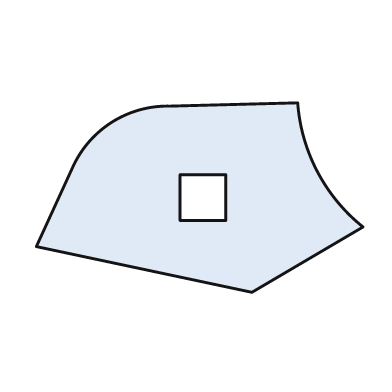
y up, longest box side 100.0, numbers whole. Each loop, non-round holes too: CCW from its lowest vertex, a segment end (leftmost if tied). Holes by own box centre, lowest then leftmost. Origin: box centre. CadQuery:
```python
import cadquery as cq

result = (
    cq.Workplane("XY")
    .moveTo(16.0, -29.0)
    .lineTo(50.0, -9.0)
    .threePointArc((36.0, 8.0), (30.0, 29.0))
    .lineTo(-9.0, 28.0)
    .threePointArc((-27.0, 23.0), (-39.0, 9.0))
    .lineTo(-50.0, -15.0)
    .close()
    .moveTo(-6.0, -7.0)
    .lineTo(8.0, -7.0)
    .lineTo(8.0, 7.0)
    .lineTo(-6.0, 7.0)
    .close()
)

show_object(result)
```